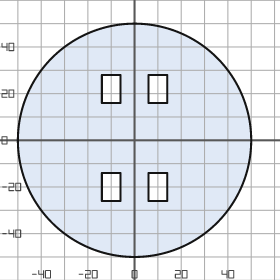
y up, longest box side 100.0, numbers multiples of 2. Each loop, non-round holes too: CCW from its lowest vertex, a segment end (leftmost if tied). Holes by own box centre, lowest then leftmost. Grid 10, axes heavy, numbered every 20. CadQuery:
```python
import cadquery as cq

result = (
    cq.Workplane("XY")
    .moveTo(0.0, 0.0)
    .circle(50.0)
    .moveTo(-14.0, -26.0)
    .lineTo(-6.0, -26.0)
    .lineTo(-6.0, -14.0)
    .lineTo(-14.0, -14.0)
    .close()
    .moveTo(6.0, -26.0)
    .lineTo(14.0, -26.0)
    .lineTo(14.0, -14.0)
    .lineTo(6.0, -14.0)
    .close()
    .moveTo(-14.0, 16.0)
    .lineTo(-6.0, 16.0)
    .lineTo(-6.0, 28.0)
    .lineTo(-14.0, 28.0)
    .close()
    .moveTo(6.0, 16.0)
    .lineTo(14.0, 16.0)
    .lineTo(14.0, 28.0)
    .lineTo(6.0, 28.0)
    .close()
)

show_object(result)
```